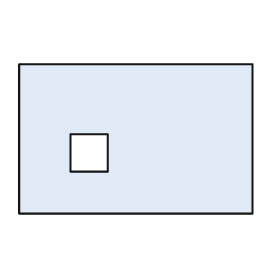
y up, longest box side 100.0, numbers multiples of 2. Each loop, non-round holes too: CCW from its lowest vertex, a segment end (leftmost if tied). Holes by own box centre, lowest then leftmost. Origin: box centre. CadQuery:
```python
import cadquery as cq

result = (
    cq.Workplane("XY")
    .moveTo(-50.0, -32.0)
    .lineTo(50.0, -32.0)
    .lineTo(50.0, 32.0)
    .lineTo(-50.0, 32.0)
    .close()
    .moveTo(-28.0, -14.0)
    .lineTo(-12.0, -14.0)
    .lineTo(-12.0, 2.0)
    .lineTo(-28.0, 2.0)
    .close()
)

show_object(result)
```